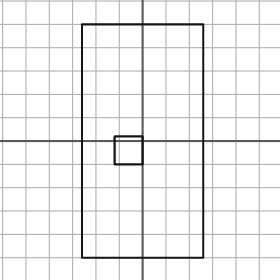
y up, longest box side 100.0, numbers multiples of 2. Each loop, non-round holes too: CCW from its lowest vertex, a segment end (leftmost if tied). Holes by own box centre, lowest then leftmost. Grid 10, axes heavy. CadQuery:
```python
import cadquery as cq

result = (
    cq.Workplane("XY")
    .moveTo(-26.0, -50.0)
    .lineTo(26.0, -50.0)
    .lineTo(26.0, 50.0)
    .lineTo(-26.0, 50.0)
    .close()
    .moveTo(-12.0, -10.0)
    .lineTo(0.0, -10.0)
    .lineTo(0.0, 2.0)
    .lineTo(-12.0, 2.0)
    .close()
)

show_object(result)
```